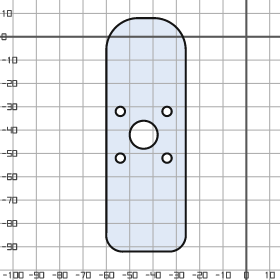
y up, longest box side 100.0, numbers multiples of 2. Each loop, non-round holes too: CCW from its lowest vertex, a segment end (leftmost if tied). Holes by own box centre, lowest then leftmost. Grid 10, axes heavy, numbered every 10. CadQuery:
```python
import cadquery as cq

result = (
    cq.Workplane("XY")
    .moveTo(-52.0, -92.0)
    .lineTo(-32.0, -92.0)
    .threePointArc((-28.0, -90.0), (-26.0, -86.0))
    .lineTo(-26.0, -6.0)
    .threePointArc((-30.0, 4.0), (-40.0, 8.0))
    .lineTo(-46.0, 8.0)
    .threePointArc((-56.0, 4.0), (-60.0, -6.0))
    .lineTo(-60.0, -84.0)
    .threePointArc((-58.0, -90.0), (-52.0, -92.0))
    .close()
    .moveTo(-54.0, -52.0)
    .circle(2.0)
    .moveTo(-34.0, -52.0)
    .circle(2.0)
    .moveTo(-44.0, -42.0)
    .circle(6.0)
    .moveTo(-54.0, -32.0)
    .circle(2.0)
    .moveTo(-34.0, -32.0)
    .circle(2.0)
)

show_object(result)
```